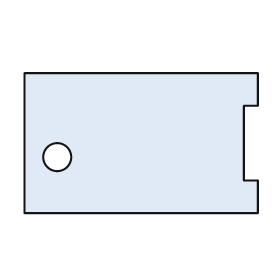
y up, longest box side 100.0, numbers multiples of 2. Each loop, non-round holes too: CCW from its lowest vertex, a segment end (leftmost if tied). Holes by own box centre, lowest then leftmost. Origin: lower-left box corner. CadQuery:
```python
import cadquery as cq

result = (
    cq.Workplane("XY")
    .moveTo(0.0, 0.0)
    .lineTo(100.0, 0.0)
    .lineTo(100.0, 14.0)
    .lineTo(94.0, 14.0)
    .lineTo(94.0, 46.0)
    .lineTo(100.0, 46.0)
    .lineTo(100.0, 60.0)
    .lineTo(0.0, 60.0)
    .close()
    .moveTo(14.0, 24.0)
    .circle(6.0)
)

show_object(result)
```